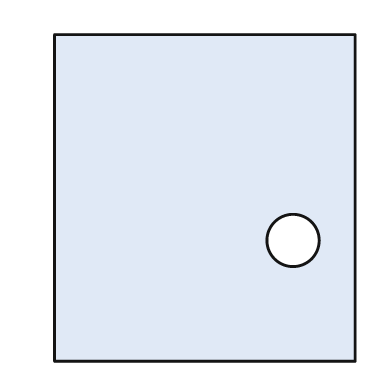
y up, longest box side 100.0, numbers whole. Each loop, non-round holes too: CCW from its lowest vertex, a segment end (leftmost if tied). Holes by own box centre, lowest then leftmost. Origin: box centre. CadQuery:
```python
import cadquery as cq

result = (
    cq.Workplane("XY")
    .moveTo(-46.0, -50.0)
    .lineTo(46.0, -50.0)
    .lineTo(46.0, 50.0)
    .lineTo(-46.0, 50.0)
    .close()
    .moveTo(27.0, -13.0)
    .circle(8.0)
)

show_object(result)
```